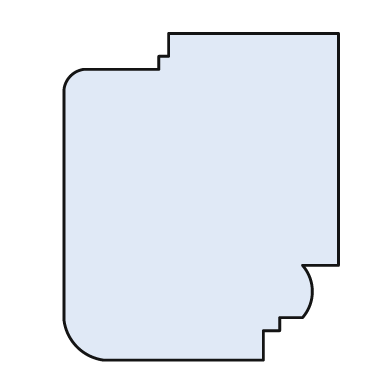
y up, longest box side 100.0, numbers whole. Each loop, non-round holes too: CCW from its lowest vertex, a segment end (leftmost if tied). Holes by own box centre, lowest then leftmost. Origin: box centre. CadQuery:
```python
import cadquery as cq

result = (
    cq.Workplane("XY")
    .moveTo(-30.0, -50.0)
    .lineTo(19.0, -50.0)
    .lineTo(19.0, -41.0)
    .lineTo(24.0, -41.0)
    .lineTo(24.0, -37.0)
    .lineTo(31.0, -37.0)
    .threePointArc((34.0, -29.0), (31.0, -21.0))
    .lineTo(42.0, -21.0)
    .lineTo(42.0, 50.0)
    .lineTo(-10.0, 50.0)
    .lineTo(-10.0, 43.0)
    .lineTo(-13.0, 43.0)
    .lineTo(-13.0, 39.0)
    .lineTo(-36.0, 39.0)
    .threePointArc((-40.0, 37.0), (-42.0, 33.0))
    .lineTo(-42.0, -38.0)
    .threePointArc((-38.0, -46.0), (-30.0, -50.0))
    .close()
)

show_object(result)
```